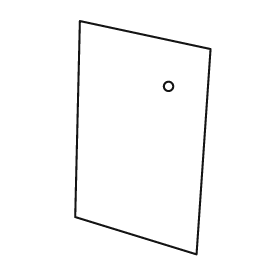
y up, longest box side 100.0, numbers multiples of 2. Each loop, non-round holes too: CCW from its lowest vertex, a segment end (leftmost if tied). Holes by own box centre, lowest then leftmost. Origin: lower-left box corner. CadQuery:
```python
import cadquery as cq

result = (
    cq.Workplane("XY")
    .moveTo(52.0, 0.0)
    .lineTo(58.0, 88.0)
    .lineTo(2.0, 100.0)
    .lineTo(0.0, 16.0)
    .close()
    .moveTo(40.0, 72.0)
    .circle(2.0)
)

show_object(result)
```